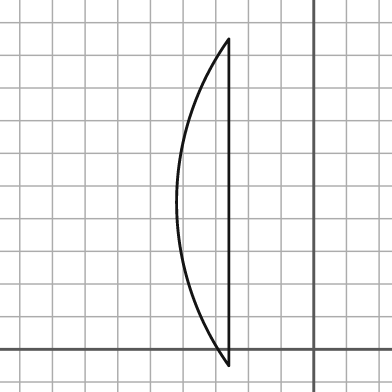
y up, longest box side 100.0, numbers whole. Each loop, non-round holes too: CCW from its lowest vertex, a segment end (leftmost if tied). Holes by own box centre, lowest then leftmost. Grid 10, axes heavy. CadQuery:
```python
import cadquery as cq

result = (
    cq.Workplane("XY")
    .moveTo(-26.0, -5.0)
    .lineTo(-26.0, 95.0)
    .threePointArc((-42.0, 45.0), (-26.0, -5.0))
    .close()
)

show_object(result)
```